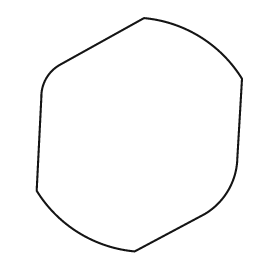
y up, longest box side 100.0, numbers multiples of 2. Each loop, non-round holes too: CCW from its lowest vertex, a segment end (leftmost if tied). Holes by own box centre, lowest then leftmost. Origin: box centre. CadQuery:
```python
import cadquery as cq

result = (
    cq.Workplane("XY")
    .moveTo(-2.0, -50.0)
    .lineTo(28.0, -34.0)
    .threePointArc((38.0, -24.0), (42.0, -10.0))
    .lineTo(44.0, 24.0)
    .threePointArc((26.0, 42.0), (2.0, 50.0))
    .lineTo(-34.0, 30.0)
    .threePointArc((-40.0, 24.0), (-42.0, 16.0))
    .lineTo(-44.0, -24.0)
    .threePointArc((-26.0, -42.0), (-2.0, -50.0))
    .close()
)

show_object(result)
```